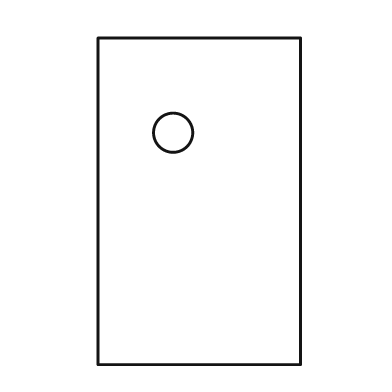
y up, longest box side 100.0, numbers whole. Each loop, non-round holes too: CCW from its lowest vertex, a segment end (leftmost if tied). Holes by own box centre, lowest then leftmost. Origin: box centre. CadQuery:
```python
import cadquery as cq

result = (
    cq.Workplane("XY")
    .moveTo(-31.0, -50.0)
    .lineTo(31.0, -50.0)
    .lineTo(31.0, 50.0)
    .lineTo(-31.0, 50.0)
    .close()
    .moveTo(-8.0, 21.0)
    .circle(6.0)
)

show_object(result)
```